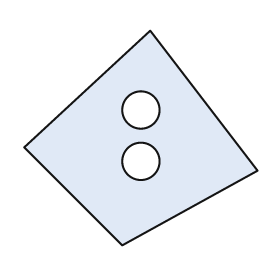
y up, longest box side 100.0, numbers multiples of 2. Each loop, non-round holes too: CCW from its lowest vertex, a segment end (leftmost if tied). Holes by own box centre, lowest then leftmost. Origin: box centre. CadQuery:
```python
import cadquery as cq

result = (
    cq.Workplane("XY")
    .moveTo(-8.0, -46.0)
    .lineTo(50.0, -14.0)
    .lineTo(4.0, 46.0)
    .lineTo(-50.0, -4.0)
    .close()
    .moveTo(0.0, -10.0)
    .circle(8.0)
    .moveTo(0.0, 12.0)
    .circle(8.0)
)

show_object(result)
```